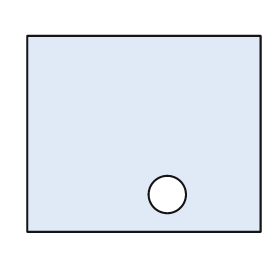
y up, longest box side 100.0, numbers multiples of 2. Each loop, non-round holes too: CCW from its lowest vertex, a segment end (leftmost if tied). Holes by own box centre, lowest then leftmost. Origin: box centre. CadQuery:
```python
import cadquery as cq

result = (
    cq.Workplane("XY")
    .moveTo(-50.0, -42.0)
    .lineTo(50.0, -42.0)
    .lineTo(50.0, 42.0)
    .lineTo(-50.0, 42.0)
    .close()
    .moveTo(10.0, -26.0)
    .circle(8.0)
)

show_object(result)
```